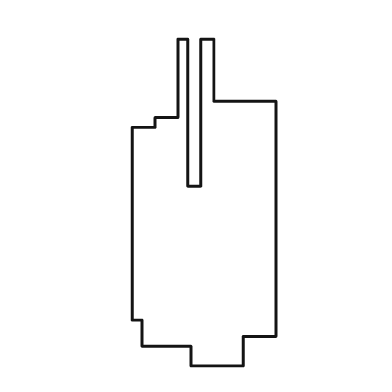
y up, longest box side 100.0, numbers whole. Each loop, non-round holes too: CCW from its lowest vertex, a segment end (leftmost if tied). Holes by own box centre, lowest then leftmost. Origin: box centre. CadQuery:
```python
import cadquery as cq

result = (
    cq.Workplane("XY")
    .moveTo(-4.0, -50.0)
    .lineTo(12.0, -50.0)
    .lineTo(12.0, -41.0)
    .lineTo(22.0, -41.0)
    .lineTo(22.0, 31.0)
    .lineTo(3.0, 31.0)
    .lineTo(3.0, 50.0)
    .lineTo(-1.0, 50.0)
    .lineTo(-1.0, 5.0)
    .lineTo(-5.0, 5.0)
    .lineTo(-5.0, 50.0)
    .lineTo(-8.0, 50.0)
    .lineTo(-8.0, 26.0)
    .lineTo(-15.0, 26.0)
    .lineTo(-15.0, 23.0)
    .lineTo(-22.0, 23.0)
    .lineTo(-22.0, -36.0)
    .lineTo(-19.0, -36.0)
    .lineTo(-19.0, -44.0)
    .lineTo(-4.0, -44.0)
    .close()
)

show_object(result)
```